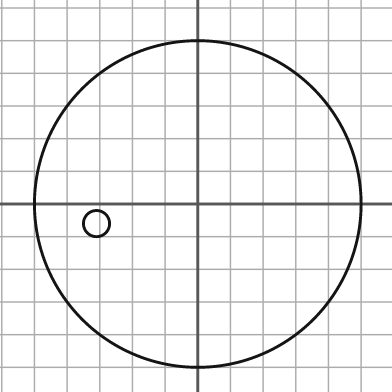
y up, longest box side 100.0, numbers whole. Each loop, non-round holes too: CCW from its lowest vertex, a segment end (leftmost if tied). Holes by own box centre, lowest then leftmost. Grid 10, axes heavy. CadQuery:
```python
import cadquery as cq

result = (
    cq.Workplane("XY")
    .moveTo(0.0, 0.0)
    .circle(50.0)
    .moveTo(-31.0, -6.0)
    .circle(4.0)
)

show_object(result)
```